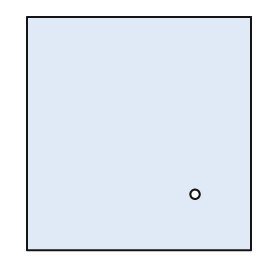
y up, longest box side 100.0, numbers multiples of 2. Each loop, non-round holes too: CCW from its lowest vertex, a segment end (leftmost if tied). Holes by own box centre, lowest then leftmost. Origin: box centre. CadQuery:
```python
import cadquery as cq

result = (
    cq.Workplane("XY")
    .moveTo(-48.0, -50.0)
    .lineTo(48.0, -50.0)
    .lineTo(48.0, 50.0)
    .lineTo(-48.0, 50.0)
    .close()
    .moveTo(24.0, -26.0)
    .circle(2.0)
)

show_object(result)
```